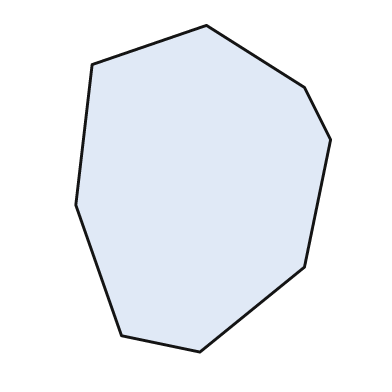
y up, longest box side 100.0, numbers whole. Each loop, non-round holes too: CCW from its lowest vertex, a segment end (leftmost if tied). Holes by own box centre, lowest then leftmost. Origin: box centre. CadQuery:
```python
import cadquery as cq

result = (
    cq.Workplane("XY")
    .moveTo(-1.0, -50.0)
    .lineTo(31.0, -24.0)
    .lineTo(39.0, 15.0)
    .lineTo(31.0, 31.0)
    .lineTo(1.0, 50.0)
    .lineTo(-34.0, 38.0)
    .lineTo(-39.0, -5.0)
    .lineTo(-25.0, -45.0)
    .close()
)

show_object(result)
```